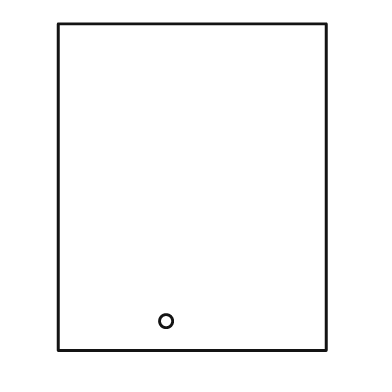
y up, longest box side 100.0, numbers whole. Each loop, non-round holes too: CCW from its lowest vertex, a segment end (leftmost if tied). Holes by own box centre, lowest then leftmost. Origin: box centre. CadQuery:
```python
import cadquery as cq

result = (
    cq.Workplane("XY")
    .moveTo(-41.0, -50.0)
    .lineTo(41.0, -50.0)
    .lineTo(41.0, 50.0)
    .lineTo(-41.0, 50.0)
    .close()
    .moveTo(-8.0, -41.0)
    .circle(2.0)
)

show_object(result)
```